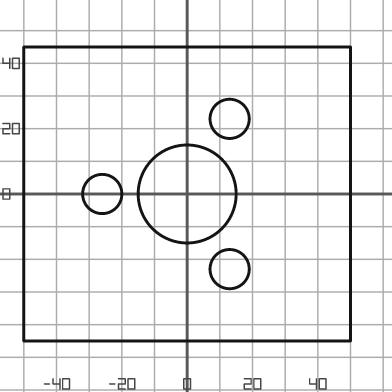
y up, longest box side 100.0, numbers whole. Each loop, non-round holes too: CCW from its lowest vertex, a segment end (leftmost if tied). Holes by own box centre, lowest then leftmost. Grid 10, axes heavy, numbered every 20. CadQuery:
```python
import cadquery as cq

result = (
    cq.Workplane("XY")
    .moveTo(-50.0, -45.0)
    .lineTo(50.0, -45.0)
    .lineTo(50.0, 45.0)
    .lineTo(-50.0, 45.0)
    .close()
    .moveTo(13.0, -23.0)
    .circle(6.0)
    .moveTo(-26.0, 0.0)
    .circle(6.0)
    .moveTo(0.0, 0.0)
    .circle(15.0)
    .moveTo(13.0, 23.0)
    .circle(6.0)
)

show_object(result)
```